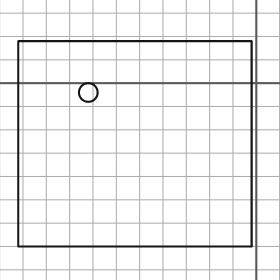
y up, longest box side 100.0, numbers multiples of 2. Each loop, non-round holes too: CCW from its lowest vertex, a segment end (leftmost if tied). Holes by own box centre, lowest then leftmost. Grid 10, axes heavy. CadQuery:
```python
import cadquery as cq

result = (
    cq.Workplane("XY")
    .moveTo(-102.0, -70.0)
    .lineTo(-2.0, -70.0)
    .lineTo(-2.0, 18.0)
    .lineTo(-102.0, 18.0)
    .close()
    .moveTo(-72.0, -4.0)
    .circle(4.0)
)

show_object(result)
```